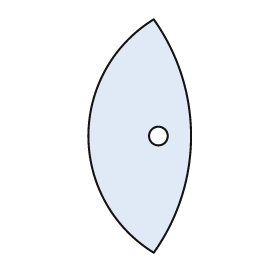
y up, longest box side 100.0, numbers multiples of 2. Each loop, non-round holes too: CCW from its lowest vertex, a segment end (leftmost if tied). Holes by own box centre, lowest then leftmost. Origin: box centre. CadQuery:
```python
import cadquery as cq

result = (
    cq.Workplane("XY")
    .moveTo(6.0, -50.0)
    .threePointArc((22.0, 0.0), (6.0, 50.0))
    .threePointArc((-22.0, 0.0), (6.0, -50.0))
    .close()
    .moveTo(8.0, 0.0)
    .circle(4.0)
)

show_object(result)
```